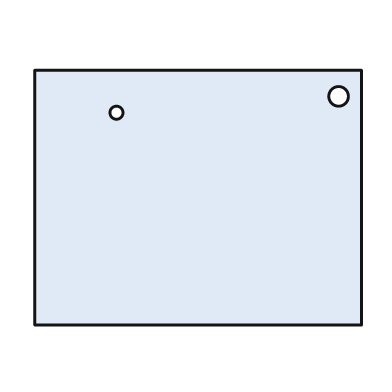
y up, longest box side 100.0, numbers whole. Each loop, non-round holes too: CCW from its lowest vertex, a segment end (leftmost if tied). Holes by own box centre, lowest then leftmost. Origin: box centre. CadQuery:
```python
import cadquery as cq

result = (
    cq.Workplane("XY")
    .moveTo(-50.0, -39.0)
    .lineTo(50.0, -39.0)
    .lineTo(50.0, 39.0)
    .lineTo(-50.0, 39.0)
    .close()
    .moveTo(-25.0, 26.0)
    .circle(2.0)
    .moveTo(43.0, 31.0)
    .circle(3.0)
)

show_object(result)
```